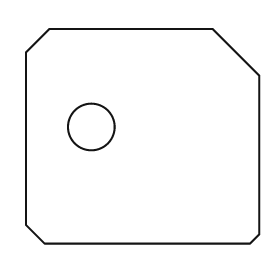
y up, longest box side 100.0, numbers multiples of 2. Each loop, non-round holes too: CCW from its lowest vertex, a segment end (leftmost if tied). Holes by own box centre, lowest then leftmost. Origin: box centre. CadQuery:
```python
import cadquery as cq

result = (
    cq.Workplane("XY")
    .moveTo(-42.0, -46.0)
    .lineTo(46.0, -46.0)
    .lineTo(50.0, -42.0)
    .lineTo(50.0, 26.0)
    .lineTo(30.0, 46.0)
    .lineTo(-40.0, 46.0)
    .lineTo(-50.0, 36.0)
    .lineTo(-50.0, -38.0)
    .close()
    .moveTo(-22.0, 4.0)
    .circle(10.0)
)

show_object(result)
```